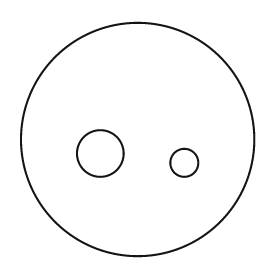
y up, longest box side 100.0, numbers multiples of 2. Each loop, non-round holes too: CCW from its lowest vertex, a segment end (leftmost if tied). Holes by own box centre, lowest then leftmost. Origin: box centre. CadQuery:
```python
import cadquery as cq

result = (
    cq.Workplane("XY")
    .moveTo(0.0, 0.0)
    .circle(50.0)
    .moveTo(20.0, -10.0)
    .circle(6.0)
    .moveTo(-16.0, -6.0)
    .circle(10.0)
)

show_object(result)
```